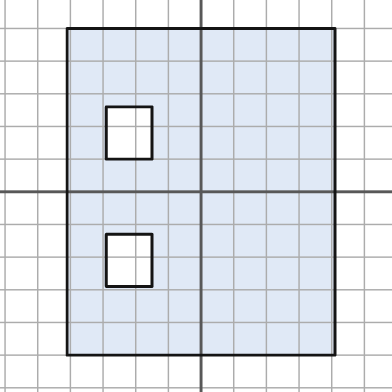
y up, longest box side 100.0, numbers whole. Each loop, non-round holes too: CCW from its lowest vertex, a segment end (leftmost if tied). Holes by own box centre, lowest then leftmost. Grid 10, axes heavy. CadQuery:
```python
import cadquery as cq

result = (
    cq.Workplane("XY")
    .moveTo(-41.0, -50.0)
    .lineTo(41.0, -50.0)
    .lineTo(41.0, 50.0)
    .lineTo(-41.0, 50.0)
    .close()
    .moveTo(-29.0, -29.0)
    .lineTo(-15.0, -29.0)
    .lineTo(-15.0, -13.0)
    .lineTo(-29.0, -13.0)
    .close()
    .moveTo(-29.0, 10.0)
    .lineTo(-15.0, 10.0)
    .lineTo(-15.0, 26.0)
    .lineTo(-29.0, 26.0)
    .close()
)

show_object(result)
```